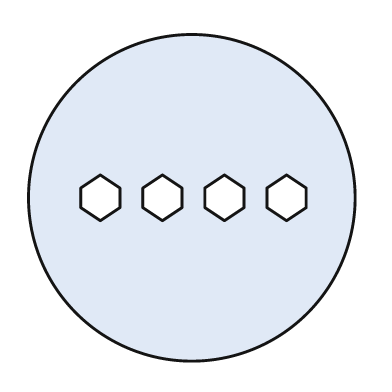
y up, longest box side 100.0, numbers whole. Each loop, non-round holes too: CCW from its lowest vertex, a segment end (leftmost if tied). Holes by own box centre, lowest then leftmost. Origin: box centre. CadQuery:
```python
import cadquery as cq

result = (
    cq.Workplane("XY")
    .moveTo(0.0, 0.0)
    .circle(50.0)
    .moveTo(-28.0, -7.0)
    .lineTo(-22.0, -3.0)
    .lineTo(-22.0, 3.0)
    .lineTo(-28.0, 7.0)
    .lineTo(-34.0, 3.0)
    .lineTo(-34.0, -3.0)
    .close()
    .moveTo(-9.0, -7.0)
    .lineTo(-3.0, -3.0)
    .lineTo(-3.0, 3.0)
    .lineTo(-9.0, 7.0)
    .lineTo(-15.0, 3.0)
    .lineTo(-15.0, -3.0)
    .close()
    .moveTo(10.0, -7.0)
    .lineTo(16.0, -3.0)
    .lineTo(16.0, 3.0)
    .lineTo(10.0, 7.0)
    .lineTo(4.0, 3.0)
    .lineTo(4.0, -3.0)
    .close()
    .moveTo(29.0, -7.0)
    .lineTo(35.0, -3.0)
    .lineTo(35.0, 3.0)
    .lineTo(29.0, 7.0)
    .lineTo(23.0, 3.0)
    .lineTo(23.0, -3.0)
    .close()
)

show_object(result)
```